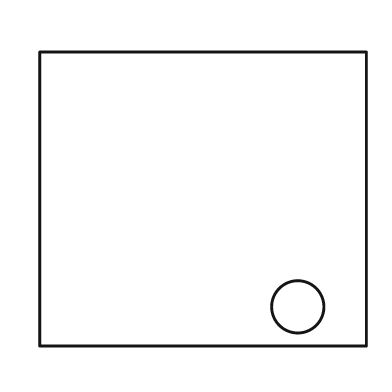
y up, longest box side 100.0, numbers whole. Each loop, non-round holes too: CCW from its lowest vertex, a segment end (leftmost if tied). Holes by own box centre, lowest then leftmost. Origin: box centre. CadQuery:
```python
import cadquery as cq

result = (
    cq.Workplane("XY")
    .moveTo(-50.0, -45.0)
    .lineTo(50.0, -45.0)
    .lineTo(50.0, 45.0)
    .lineTo(-50.0, 45.0)
    .close()
    .moveTo(29.0, -33.0)
    .circle(8.0)
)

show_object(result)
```